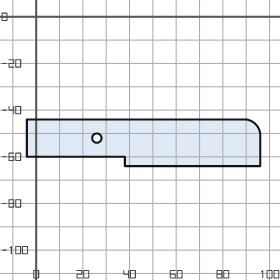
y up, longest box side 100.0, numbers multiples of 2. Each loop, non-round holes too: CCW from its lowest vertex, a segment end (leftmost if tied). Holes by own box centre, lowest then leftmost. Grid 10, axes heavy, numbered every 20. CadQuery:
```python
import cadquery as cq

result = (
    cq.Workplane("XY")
    .moveTo(38.0, -64.0)
    .lineTo(96.0, -64.0)
    .lineTo(96.0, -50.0)
    .threePointArc((94.0, -46.0), (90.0, -44.0))
    .lineTo(-4.0, -44.0)
    .lineTo(-4.0, -60.0)
    .lineTo(38.0, -60.0)
    .close()
    .moveTo(26.0, -52.0)
    .circle(2.0)
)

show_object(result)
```